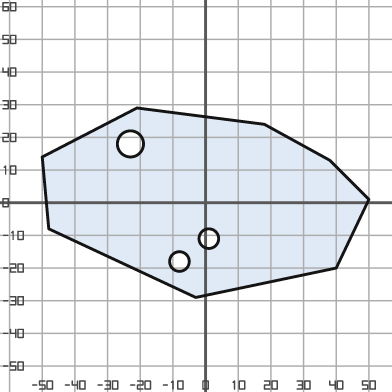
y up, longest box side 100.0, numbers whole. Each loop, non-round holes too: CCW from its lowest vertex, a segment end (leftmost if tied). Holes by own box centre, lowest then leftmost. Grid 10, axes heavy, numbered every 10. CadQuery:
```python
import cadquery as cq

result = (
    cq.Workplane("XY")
    .moveTo(-3.0, -29.0)
    .lineTo(40.0, -20.0)
    .lineTo(50.0, 1.0)
    .lineTo(38.0, 13.0)
    .lineTo(18.0, 24.0)
    .lineTo(-21.0, 29.0)
    .lineTo(-50.0, 14.0)
    .lineTo(-48.0, -8.0)
    .close()
    .moveTo(-8.0, -18.0)
    .circle(3.0)
    .moveTo(1.0, -11.0)
    .circle(3.0)
    .moveTo(-23.0, 18.0)
    .circle(4.0)
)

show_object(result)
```